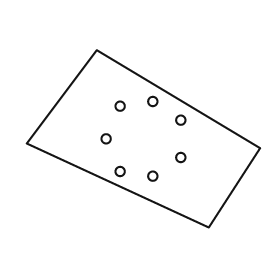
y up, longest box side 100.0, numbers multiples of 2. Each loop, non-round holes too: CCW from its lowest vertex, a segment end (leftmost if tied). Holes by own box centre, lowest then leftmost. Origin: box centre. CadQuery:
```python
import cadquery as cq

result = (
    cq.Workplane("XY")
    .moveTo(28.0, -38.0)
    .lineTo(50.0, -4.0)
    .lineTo(-20.0, 38.0)
    .lineTo(-50.0, -2.0)
    .close()
    .moveTo(4.0, -16.0)
    .circle(2.0)
    .moveTo(-10.0, -14.0)
    .circle(2.0)
    .moveTo(16.0, -8.0)
    .circle(2.0)
    .moveTo(-16.0, 0.0)
    .circle(2.0)
    .moveTo(16.0, 8.0)
    .circle(2.0)
    .moveTo(-10.0, 14.0)
    .circle(2.0)
    .moveTo(4.0, 16.0)
    .circle(2.0)
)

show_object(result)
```